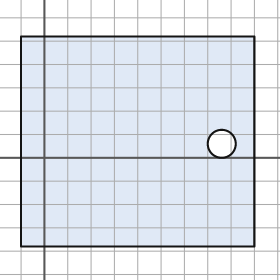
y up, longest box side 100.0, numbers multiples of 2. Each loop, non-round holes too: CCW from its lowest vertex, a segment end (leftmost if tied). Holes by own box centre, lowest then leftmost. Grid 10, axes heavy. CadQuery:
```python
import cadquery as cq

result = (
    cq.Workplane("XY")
    .moveTo(-10.0, -38.0)
    .lineTo(90.0, -38.0)
    .lineTo(90.0, 52.0)
    .lineTo(-10.0, 52.0)
    .close()
    .moveTo(76.0, 6.0)
    .circle(6.0)
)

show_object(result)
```